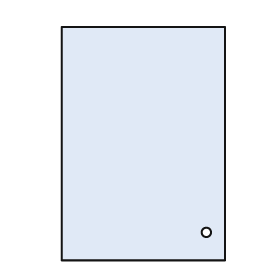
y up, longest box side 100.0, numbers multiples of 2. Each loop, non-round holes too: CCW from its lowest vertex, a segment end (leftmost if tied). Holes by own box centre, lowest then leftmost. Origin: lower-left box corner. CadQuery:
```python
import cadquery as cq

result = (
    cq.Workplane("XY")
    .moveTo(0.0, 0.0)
    .lineTo(70.0, 0.0)
    .lineTo(70.0, 100.0)
    .lineTo(0.0, 100.0)
    .close()
    .moveTo(62.0, 12.0)
    .circle(2.0)
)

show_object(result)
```